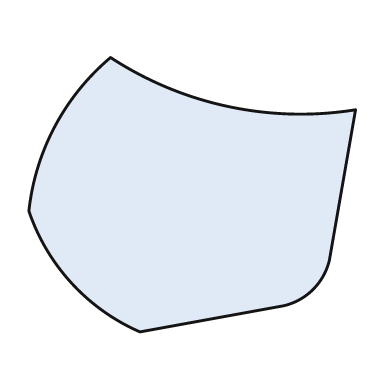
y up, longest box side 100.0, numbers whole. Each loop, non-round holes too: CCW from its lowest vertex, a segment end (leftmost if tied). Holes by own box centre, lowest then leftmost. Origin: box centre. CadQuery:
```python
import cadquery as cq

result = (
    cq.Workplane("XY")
    .moveTo(-16.0, -42.0)
    .lineTo(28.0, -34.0)
    .threePointArc((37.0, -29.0), (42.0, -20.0))
    .lineTo(50.0, 26.0)
    .threePointArc((11.0, 27.0), (-25.0, 42.0))
    .threePointArc((-42.0, 21.0), (-50.0, -5.0))
    .threePointArc((-37.0, -27.0), (-16.0, -42.0))
    .close()
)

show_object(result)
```